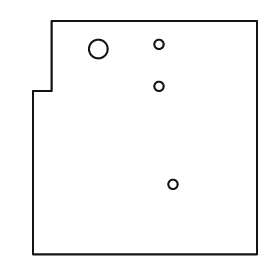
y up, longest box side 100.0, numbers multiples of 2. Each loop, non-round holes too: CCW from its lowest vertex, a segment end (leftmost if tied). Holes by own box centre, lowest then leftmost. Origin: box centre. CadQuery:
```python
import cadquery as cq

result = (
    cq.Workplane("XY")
    .moveTo(-48.0, -50.0)
    .lineTo(48.0, -50.0)
    .lineTo(48.0, 50.0)
    .lineTo(-40.0, 50.0)
    .lineTo(-40.0, 20.0)
    .lineTo(-48.0, 20.0)
    .close()
    .moveTo(12.0, -20.0)
    .circle(2.0)
    .moveTo(6.0, 22.0)
    .circle(2.0)
    .moveTo(-20.0, 38.0)
    .circle(4.0)
    .moveTo(6.0, 40.0)
    .circle(2.0)
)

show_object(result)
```